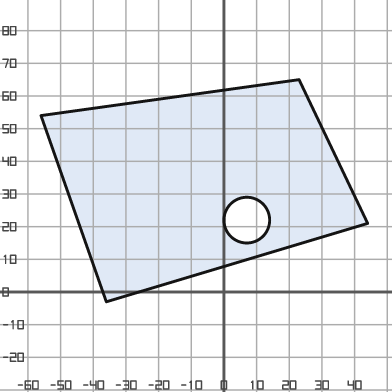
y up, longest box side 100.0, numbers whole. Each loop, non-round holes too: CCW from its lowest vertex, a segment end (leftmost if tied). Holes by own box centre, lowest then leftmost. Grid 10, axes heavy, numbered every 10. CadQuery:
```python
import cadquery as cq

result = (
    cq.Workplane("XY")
    .moveTo(-36.0, -3.0)
    .lineTo(44.0, 21.0)
    .lineTo(23.0, 65.0)
    .lineTo(-56.0, 54.0)
    .close()
    .moveTo(7.0, 22.0)
    .circle(7.0)
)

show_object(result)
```